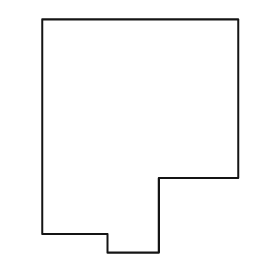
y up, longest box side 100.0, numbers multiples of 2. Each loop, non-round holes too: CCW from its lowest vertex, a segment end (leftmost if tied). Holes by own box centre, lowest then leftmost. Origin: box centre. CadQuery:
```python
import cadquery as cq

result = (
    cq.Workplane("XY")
    .moveTo(-14.0, -50.0)
    .lineTo(8.0, -50.0)
    .lineTo(8.0, -18.0)
    .lineTo(42.0, -18.0)
    .lineTo(42.0, 50.0)
    .lineTo(-42.0, 50.0)
    .lineTo(-42.0, -42.0)
    .lineTo(-14.0, -42.0)
    .close()
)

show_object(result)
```